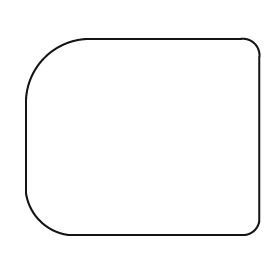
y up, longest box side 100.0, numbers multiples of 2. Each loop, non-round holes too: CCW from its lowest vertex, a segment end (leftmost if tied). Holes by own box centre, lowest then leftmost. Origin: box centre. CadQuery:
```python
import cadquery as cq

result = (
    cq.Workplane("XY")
    .moveTo(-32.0, -42.0)
    .lineTo(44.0, -42.0)
    .threePointArc((48.0, -40.0), (50.0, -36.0))
    .lineTo(50.0, 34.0)
    .threePointArc((48.0, 40.0), (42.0, 42.0))
    .lineTo(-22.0, 42.0)
    .threePointArc((-42.0, 34.0), (-50.0, 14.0))
    .lineTo(-50.0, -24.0)
    .threePointArc((-44.0, -36.0), (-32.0, -42.0))
    .close()
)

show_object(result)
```